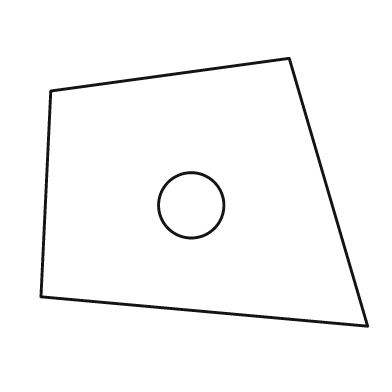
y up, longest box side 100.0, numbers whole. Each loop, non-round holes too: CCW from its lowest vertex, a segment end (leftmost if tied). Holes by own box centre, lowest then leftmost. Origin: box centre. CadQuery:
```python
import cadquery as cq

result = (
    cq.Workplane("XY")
    .moveTo(50.0, -41.0)
    .lineTo(26.0, 41.0)
    .lineTo(-47.0, 31.0)
    .lineTo(-50.0, -32.0)
    .close()
    .moveTo(-4.0, -4.0)
    .circle(10.0)
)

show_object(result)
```